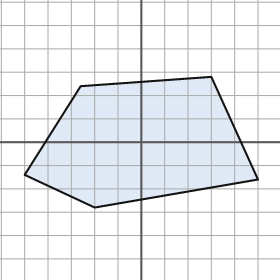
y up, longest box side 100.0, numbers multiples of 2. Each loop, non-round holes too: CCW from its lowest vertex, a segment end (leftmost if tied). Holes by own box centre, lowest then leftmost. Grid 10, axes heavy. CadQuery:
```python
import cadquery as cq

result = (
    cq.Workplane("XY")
    .moveTo(-20.0, -28.0)
    .lineTo(50.0, -16.0)
    .lineTo(30.0, 28.0)
    .lineTo(-26.0, 24.0)
    .lineTo(-50.0, -14.0)
    .close()
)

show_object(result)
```